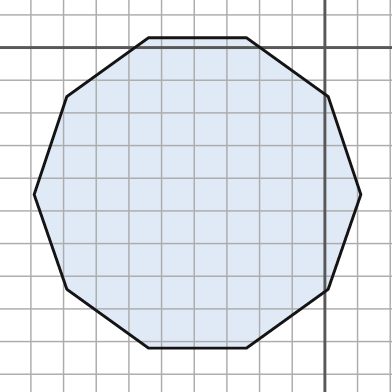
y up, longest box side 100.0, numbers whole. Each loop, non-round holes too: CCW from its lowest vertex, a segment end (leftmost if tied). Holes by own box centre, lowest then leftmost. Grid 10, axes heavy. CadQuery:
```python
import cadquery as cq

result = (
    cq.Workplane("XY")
    .moveTo(-54.0, -92.0)
    .lineTo(-24.0, -92.0)
    .lineTo(1.0, -74.0)
    .lineTo(11.0, -45.0)
    .lineTo(1.0, -15.0)
    .lineTo(-24.0, 3.0)
    .lineTo(-54.0, 3.0)
    .lineTo(-79.0, -15.0)
    .lineTo(-89.0, -45.0)
    .lineTo(-79.0, -74.0)
    .close()
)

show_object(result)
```